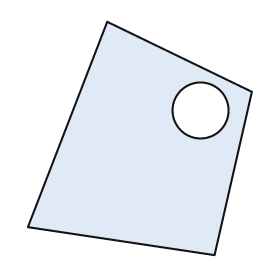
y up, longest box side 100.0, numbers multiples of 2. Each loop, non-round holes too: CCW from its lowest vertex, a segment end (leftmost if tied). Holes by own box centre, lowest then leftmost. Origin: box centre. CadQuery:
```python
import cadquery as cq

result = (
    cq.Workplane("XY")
    .moveTo(32.0, -50.0)
    .lineTo(48.0, 20.0)
    .lineTo(-14.0, 50.0)
    .lineTo(-48.0, -38.0)
    .close()
    .moveTo(26.0, 12.0)
    .circle(12.0)
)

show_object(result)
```